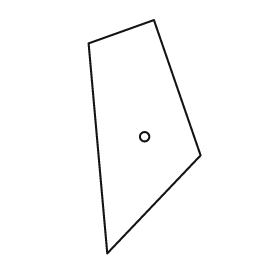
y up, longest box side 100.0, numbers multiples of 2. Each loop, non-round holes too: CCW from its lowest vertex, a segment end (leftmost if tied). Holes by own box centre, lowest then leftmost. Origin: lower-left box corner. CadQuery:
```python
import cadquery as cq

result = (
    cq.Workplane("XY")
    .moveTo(8.0, 0.0)
    .lineTo(48.0, 42.0)
    .lineTo(28.0, 100.0)
    .lineTo(0.0, 90.0)
    .close()
    .moveTo(24.0, 50.0)
    .circle(2.0)
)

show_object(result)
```